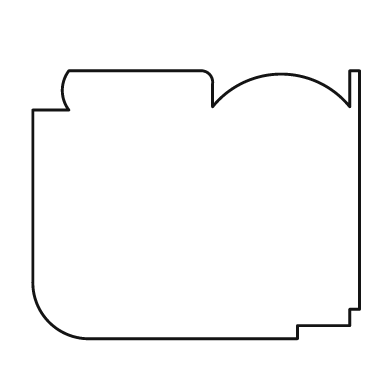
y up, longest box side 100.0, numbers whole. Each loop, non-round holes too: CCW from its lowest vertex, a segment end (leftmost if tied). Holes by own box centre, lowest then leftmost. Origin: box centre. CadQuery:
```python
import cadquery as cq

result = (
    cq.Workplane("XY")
    .moveTo(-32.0, -41.0)
    .lineTo(31.0, -41.0)
    .lineTo(31.0, -37.0)
    .lineTo(47.0, -37.0)
    .lineTo(47.0, -32.0)
    .lineTo(50.0, -32.0)
    .lineTo(50.0, 41.0)
    .lineTo(47.0, 41.0)
    .lineTo(47.0, 30.0)
    .threePointArc((26.0, 40.0), (5.0, 30.0))
    .lineTo(5.0, 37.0)
    .threePointArc((4.0, 40.0), (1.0, 41.0))
    .lineTo(-39.0, 41.0)
    .threePointArc((-41.0, 35.0), (-39.0, 29.0))
    .lineTo(-50.0, 29.0)
    .lineTo(-50.0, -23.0)
    .threePointArc((-45.0, -36.0), (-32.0, -41.0))
    .close()
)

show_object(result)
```